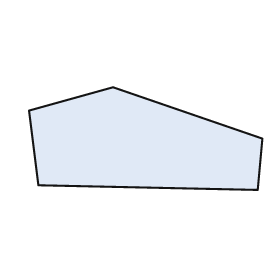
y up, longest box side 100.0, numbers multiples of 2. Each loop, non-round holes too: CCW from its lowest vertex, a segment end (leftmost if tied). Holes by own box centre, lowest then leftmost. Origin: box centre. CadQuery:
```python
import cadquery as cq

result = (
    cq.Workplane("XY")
    .moveTo(48.0, -22.0)
    .lineTo(50.0, 0.0)
    .lineTo(-14.0, 22.0)
    .lineTo(-50.0, 12.0)
    .lineTo(-46.0, -20.0)
    .close()
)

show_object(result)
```